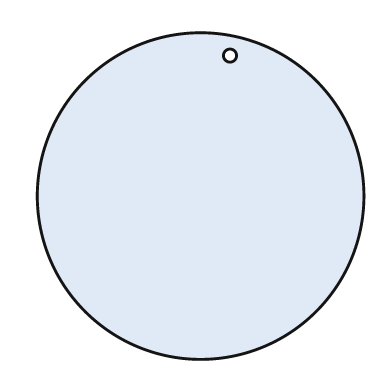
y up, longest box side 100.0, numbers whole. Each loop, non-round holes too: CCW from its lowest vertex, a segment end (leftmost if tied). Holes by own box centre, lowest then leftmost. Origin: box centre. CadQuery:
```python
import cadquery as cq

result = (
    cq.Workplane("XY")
    .moveTo(0.0, 0.0)
    .circle(50.0)
    .moveTo(9.0, 43.0)
    .circle(2.0)
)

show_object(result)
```